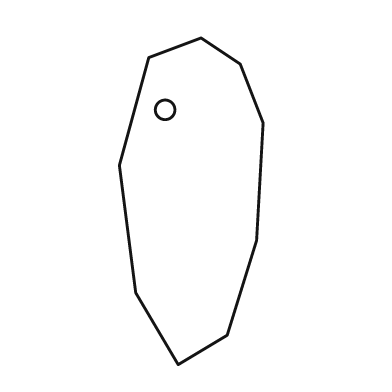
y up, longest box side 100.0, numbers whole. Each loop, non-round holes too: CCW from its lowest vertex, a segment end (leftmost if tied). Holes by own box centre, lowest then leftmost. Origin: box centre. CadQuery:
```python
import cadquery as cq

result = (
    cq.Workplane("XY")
    .moveTo(-4.0, -50.0)
    .lineTo(11.0, -41.0)
    .lineTo(20.0, -12.0)
    .lineTo(22.0, 24.0)
    .lineTo(15.0, 42.0)
    .lineTo(3.0, 50.0)
    .lineTo(-13.0, 44.0)
    .lineTo(-22.0, 11.0)
    .lineTo(-17.0, -28.0)
    .close()
    .moveTo(-8.0, 28.0)
    .circle(3.0)
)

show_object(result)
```